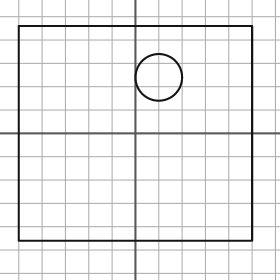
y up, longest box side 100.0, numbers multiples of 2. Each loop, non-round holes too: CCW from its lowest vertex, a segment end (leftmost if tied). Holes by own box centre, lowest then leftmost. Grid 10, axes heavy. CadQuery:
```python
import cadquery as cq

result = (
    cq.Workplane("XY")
    .moveTo(-50.0, -46.0)
    .lineTo(50.0, -46.0)
    .lineTo(50.0, 46.0)
    .lineTo(-50.0, 46.0)
    .close()
    .moveTo(10.0, 24.0)
    .circle(10.0)
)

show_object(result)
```